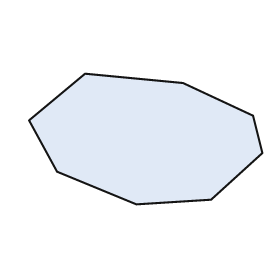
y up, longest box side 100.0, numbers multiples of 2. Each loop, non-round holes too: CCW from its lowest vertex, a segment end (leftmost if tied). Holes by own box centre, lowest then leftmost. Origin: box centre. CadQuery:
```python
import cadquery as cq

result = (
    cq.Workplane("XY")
    .moveTo(-4.0, -28.0)
    .lineTo(28.0, -26.0)
    .lineTo(50.0, -6.0)
    .lineTo(46.0, 10.0)
    .lineTo(16.0, 24.0)
    .lineTo(-26.0, 28.0)
    .lineTo(-50.0, 8.0)
    .lineTo(-38.0, -14.0)
    .close()
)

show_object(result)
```